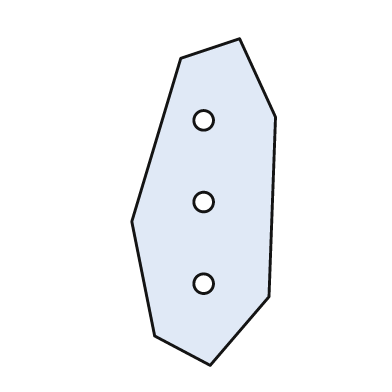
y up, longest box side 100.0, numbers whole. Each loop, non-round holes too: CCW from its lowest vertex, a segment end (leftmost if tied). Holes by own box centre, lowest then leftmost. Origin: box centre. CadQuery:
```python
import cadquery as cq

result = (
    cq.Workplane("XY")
    .moveTo(2.0, -50.0)
    .lineTo(20.0, -29.0)
    .lineTo(22.0, 26.0)
    .lineTo(11.0, 50.0)
    .lineTo(-7.0, 44.0)
    .lineTo(-22.0, -6.0)
    .lineTo(-15.0, -41.0)
    .close()
    .moveTo(0.0, -25.0)
    .circle(3.0)
    .moveTo(0.0, 0.0)
    .circle(3.0)
    .moveTo(0.0, 25.0)
    .circle(3.0)
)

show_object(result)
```